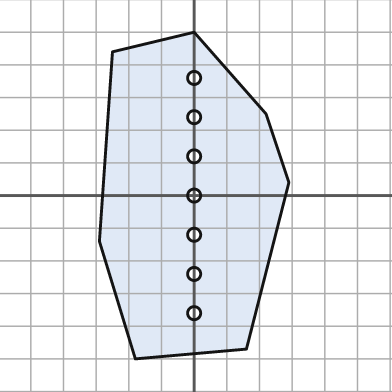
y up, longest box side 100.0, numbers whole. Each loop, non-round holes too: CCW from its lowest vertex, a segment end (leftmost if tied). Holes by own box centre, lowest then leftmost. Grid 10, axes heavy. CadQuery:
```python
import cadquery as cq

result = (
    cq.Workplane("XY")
    .moveTo(-18.0, -50.0)
    .lineTo(16.0, -47.0)
    .lineTo(29.0, 4.0)
    .lineTo(22.0, 25.0)
    .lineTo(0.0, 50.0)
    .lineTo(-25.0, 44.0)
    .lineTo(-29.0, -14.0)
    .close()
    .moveTo(0.0, -36.0)
    .circle(2.0)
    .moveTo(0.0, -24.0)
    .circle(2.0)
    .moveTo(0.0, -12.0)
    .circle(2.0)
    .moveTo(0.0, 0.0)
    .circle(2.0)
    .moveTo(0.0, 12.0)
    .circle(2.0)
    .moveTo(0.0, 24.0)
    .circle(2.0)
    .moveTo(0.0, 36.0)
    .circle(2.0)
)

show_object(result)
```